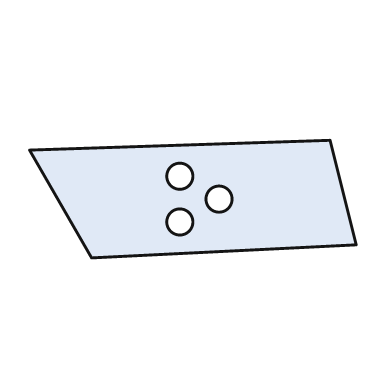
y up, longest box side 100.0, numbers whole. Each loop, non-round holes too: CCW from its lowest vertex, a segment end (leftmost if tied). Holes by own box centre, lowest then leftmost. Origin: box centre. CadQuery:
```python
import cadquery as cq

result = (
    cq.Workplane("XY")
    .moveTo(-31.0, -18.0)
    .lineTo(50.0, -14.0)
    .lineTo(42.0, 18.0)
    .lineTo(-50.0, 15.0)
    .close()
    .moveTo(-4.0, -7.0)
    .circle(4.0)
    .moveTo(8.0, 0.0)
    .circle(4.0)
    .moveTo(-4.0, 7.0)
    .circle(4.0)
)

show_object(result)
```